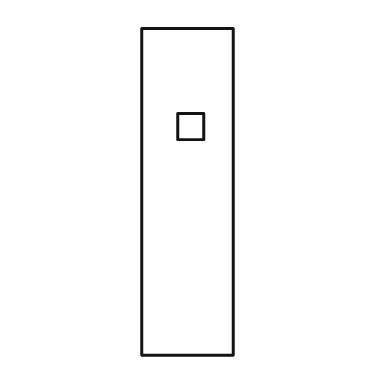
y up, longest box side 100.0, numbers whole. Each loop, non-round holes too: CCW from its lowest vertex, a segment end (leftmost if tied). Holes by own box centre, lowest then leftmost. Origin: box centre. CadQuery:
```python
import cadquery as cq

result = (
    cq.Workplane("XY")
    .moveTo(-14.0, -50.0)
    .lineTo(14.0, -50.0)
    .lineTo(14.0, 50.0)
    .lineTo(-14.0, 50.0)
    .close()
    .moveTo(-3.0, 16.0)
    .lineTo(5.0, 16.0)
    .lineTo(5.0, 24.0)
    .lineTo(-3.0, 24.0)
    .close()
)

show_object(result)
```